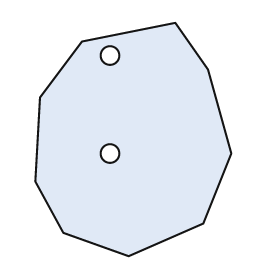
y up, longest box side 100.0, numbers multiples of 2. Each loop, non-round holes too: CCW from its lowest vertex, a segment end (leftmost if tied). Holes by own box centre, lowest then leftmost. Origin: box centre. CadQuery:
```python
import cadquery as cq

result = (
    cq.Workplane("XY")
    .moveTo(-2.0, -50.0)
    .lineTo(30.0, -36.0)
    .lineTo(42.0, -6.0)
    .lineTo(32.0, 30.0)
    .lineTo(18.0, 50.0)
    .lineTo(-22.0, 42.0)
    .lineTo(-40.0, 18.0)
    .lineTo(-42.0, -18.0)
    .lineTo(-30.0, -40.0)
    .close()
    .moveTo(-10.0, -6.0)
    .circle(4.0)
    .moveTo(-10.0, 36.0)
    .circle(4.0)
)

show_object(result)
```